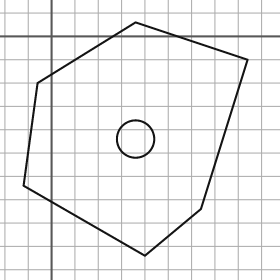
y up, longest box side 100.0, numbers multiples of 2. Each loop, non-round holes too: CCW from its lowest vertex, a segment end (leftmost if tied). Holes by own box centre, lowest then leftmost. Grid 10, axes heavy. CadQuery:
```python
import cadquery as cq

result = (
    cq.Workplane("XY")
    .moveTo(40.0, -94.0)
    .lineTo(64.0, -74.0)
    .lineTo(84.0, -10.0)
    .lineTo(36.0, 6.0)
    .lineTo(-6.0, -20.0)
    .lineTo(-12.0, -64.0)
    .close()
    .moveTo(36.0, -44.0)
    .circle(8.0)
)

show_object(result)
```